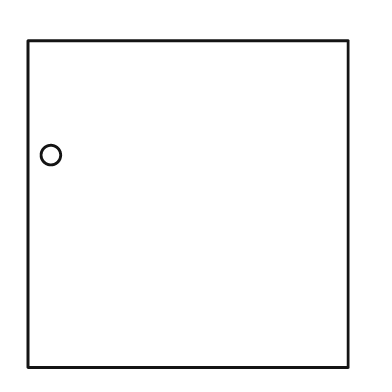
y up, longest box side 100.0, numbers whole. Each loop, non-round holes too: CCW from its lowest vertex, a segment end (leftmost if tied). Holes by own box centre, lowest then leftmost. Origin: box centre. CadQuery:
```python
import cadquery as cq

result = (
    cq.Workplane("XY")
    .moveTo(-49.0, -50.0)
    .lineTo(49.0, -50.0)
    .lineTo(49.0, 50.0)
    .lineTo(-49.0, 50.0)
    .close()
    .moveTo(-42.0, 15.0)
    .circle(3.0)
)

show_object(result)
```